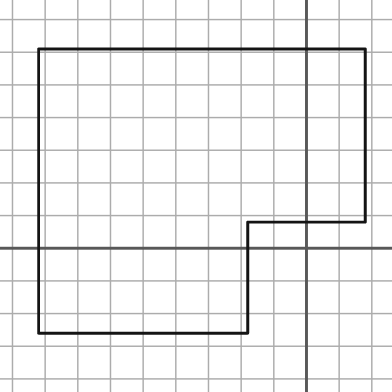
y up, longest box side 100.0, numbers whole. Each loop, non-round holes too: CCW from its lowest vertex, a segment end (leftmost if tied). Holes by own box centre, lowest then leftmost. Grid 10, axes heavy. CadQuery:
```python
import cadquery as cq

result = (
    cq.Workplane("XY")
    .moveTo(-82.0, -26.0)
    .lineTo(-18.0, -26.0)
    .lineTo(-18.0, 8.0)
    .lineTo(18.0, 8.0)
    .lineTo(18.0, 61.0)
    .lineTo(-82.0, 61.0)
    .close()
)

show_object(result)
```